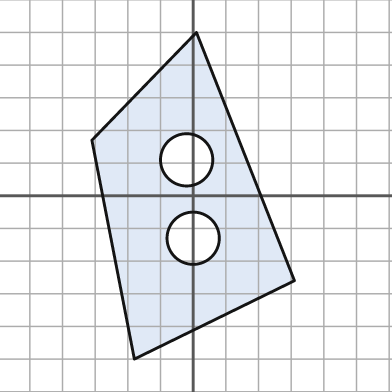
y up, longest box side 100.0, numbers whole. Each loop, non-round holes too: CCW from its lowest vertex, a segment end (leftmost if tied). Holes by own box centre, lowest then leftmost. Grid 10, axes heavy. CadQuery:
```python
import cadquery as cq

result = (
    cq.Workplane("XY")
    .moveTo(-18.0, -50.0)
    .lineTo(31.0, -26.0)
    .lineTo(1.0, 50.0)
    .lineTo(-31.0, 17.0)
    .close()
    .moveTo(0.0, -13.0)
    .circle(8.0)
    .moveTo(-2.0, 11.0)
    .circle(8.0)
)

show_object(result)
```